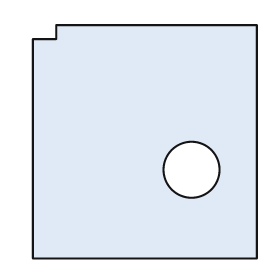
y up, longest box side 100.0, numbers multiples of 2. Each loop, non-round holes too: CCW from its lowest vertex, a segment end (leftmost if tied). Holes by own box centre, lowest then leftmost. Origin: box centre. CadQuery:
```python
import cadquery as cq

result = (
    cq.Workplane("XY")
    .moveTo(-48.0, -50.0)
    .lineTo(48.0, -50.0)
    .lineTo(48.0, 50.0)
    .lineTo(-38.0, 50.0)
    .lineTo(-38.0, 44.0)
    .lineTo(-48.0, 44.0)
    .close()
    .moveTo(20.0, -12.0)
    .circle(12.0)
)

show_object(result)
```